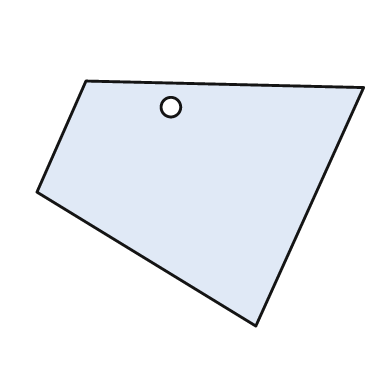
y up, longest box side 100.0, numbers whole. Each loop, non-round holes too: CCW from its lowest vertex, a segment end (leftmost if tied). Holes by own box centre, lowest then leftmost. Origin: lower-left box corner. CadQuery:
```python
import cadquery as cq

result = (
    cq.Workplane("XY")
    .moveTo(67.0, 0.0)
    .lineTo(100.0, 73.0)
    .lineTo(15.0, 75.0)
    .lineTo(0.0, 41.0)
    .close()
    .moveTo(41.0, 67.0)
    .circle(3.0)
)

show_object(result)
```